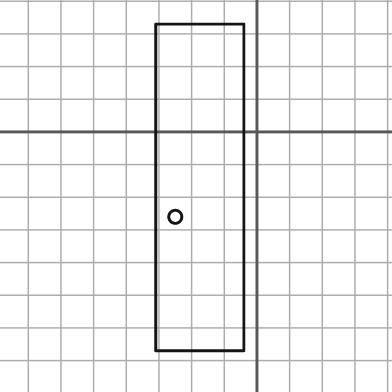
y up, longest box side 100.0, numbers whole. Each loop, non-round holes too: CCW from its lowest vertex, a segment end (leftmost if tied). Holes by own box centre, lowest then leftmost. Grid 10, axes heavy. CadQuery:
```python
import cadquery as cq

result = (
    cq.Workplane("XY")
    .moveTo(-31.0, -67.0)
    .lineTo(-4.0, -67.0)
    .lineTo(-4.0, 33.0)
    .lineTo(-31.0, 33.0)
    .close()
    .moveTo(-25.0, -26.0)
    .circle(2.0)
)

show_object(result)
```